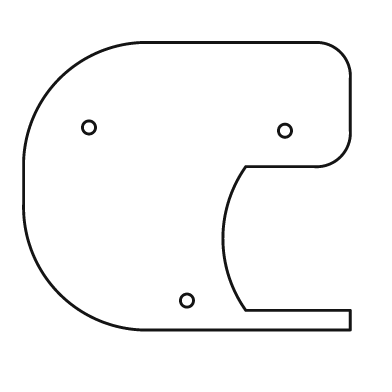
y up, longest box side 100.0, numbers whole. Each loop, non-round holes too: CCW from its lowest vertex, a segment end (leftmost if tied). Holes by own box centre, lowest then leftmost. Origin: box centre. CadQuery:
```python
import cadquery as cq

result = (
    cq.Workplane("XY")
    .moveTo(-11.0, -44.0)
    .lineTo(50.0, -44.0)
    .lineTo(50.0, -38.0)
    .lineTo(18.0, -38.0)
    .threePointArc((11.0, -16.0), (18.0, 6.0))
    .lineTo(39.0, 6.0)
    .threePointArc((47.0, 9.0), (50.0, 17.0))
    .lineTo(50.0, 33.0)
    .threePointArc((47.0, 41.0), (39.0, 44.0))
    .lineTo(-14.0, 44.0)
    .threePointArc((-39.0, 33.0), (-50.0, 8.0))
    .lineTo(-50.0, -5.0)
    .threePointArc((-39.0, -33.0), (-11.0, -44.0))
    .close()
    .moveTo(0.0, -35.0)
    .circle(2.0)
    .moveTo(30.0, 17.0)
    .circle(2.0)
    .moveTo(-30.0, 18.0)
    .circle(2.0)
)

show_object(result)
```